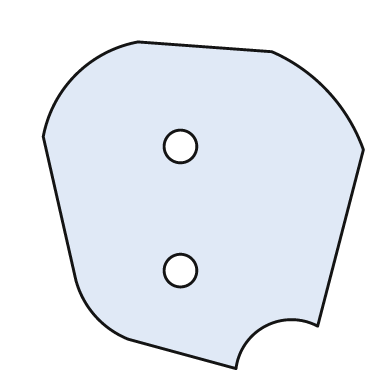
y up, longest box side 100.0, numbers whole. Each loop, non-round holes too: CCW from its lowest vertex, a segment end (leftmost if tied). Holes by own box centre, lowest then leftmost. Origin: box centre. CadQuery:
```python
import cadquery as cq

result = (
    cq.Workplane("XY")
    .moveTo(10.0, -50.0)
    .threePointArc((19.0, -37.0), (35.0, -37.0))
    .lineTo(49.0, 17.0)
    .threePointArc((38.0, 35.0), (21.0, 47.0))
    .lineTo(-20.0, 50.0)
    .threePointArc((-39.0, 40.0), (-49.0, 21.0))
    .lineTo(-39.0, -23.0)
    .threePointArc((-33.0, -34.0), (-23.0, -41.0))
    .close()
    .moveTo(-7.0, -20.0)
    .circle(5.0)
    .moveTo(-7.0, 18.0)
    .circle(5.0)
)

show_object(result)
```